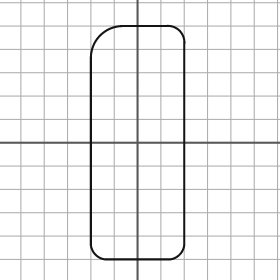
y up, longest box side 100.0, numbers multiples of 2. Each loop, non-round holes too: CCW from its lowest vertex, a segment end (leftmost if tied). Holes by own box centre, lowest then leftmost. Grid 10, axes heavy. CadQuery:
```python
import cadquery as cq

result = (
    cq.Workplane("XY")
    .moveTo(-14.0, -50.0)
    .lineTo(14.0, -50.0)
    .threePointArc((18.0, -48.0), (20.0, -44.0))
    .lineTo(20.0, 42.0)
    .threePointArc((18.0, 48.0), (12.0, 50.0))
    .lineTo(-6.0, 50.0)
    .threePointArc((-16.0, 46.0), (-20.0, 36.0))
    .lineTo(-20.0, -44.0)
    .threePointArc((-18.0, -48.0), (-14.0, -50.0))
    .close()
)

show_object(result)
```